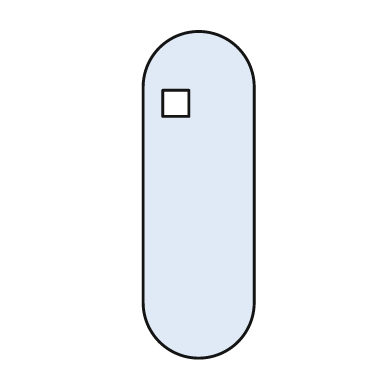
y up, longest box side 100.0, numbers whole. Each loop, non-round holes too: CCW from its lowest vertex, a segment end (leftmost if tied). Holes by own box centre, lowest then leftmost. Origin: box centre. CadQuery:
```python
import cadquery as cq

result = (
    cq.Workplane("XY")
    .moveTo(-17.0, -33.0)
    .threePointArc((0.0, -50.0), (17.0, -33.0))
    .lineTo(17.0, 33.0)
    .threePointArc((0.0, 50.0), (-17.0, 33.0))
    .close()
    .moveTo(-11.0, 24.0)
    .lineTo(-3.0, 24.0)
    .lineTo(-3.0, 32.0)
    .lineTo(-11.0, 32.0)
    .close()
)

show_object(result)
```